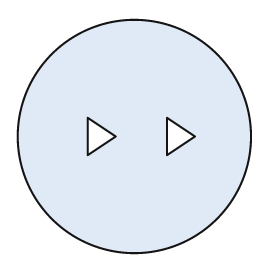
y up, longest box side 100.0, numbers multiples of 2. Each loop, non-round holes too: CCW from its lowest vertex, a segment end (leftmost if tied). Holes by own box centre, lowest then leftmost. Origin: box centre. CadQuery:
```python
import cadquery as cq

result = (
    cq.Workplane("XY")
    .moveTo(0.0, 0.0)
    .circle(50.0)
    .moveTo(-20.0, -8.0)
    .lineTo(-8.0, 0.0)
    .lineTo(-20.0, 8.0)
    .close()
    .moveTo(14.0, -8.0)
    .lineTo(26.0, 0.0)
    .lineTo(14.0, 8.0)
    .close()
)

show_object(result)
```